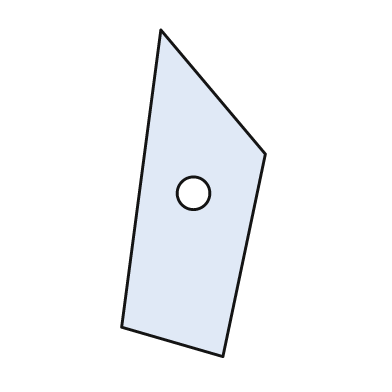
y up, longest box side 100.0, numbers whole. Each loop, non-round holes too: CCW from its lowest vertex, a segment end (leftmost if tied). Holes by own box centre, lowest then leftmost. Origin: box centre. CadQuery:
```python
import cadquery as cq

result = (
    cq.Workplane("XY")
    .moveTo(9.0, -50.0)
    .lineTo(22.0, 12.0)
    .lineTo(-10.0, 50.0)
    .lineTo(-22.0, -41.0)
    .close()
    .moveTo(0.0, 0.0)
    .circle(5.0)
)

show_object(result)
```